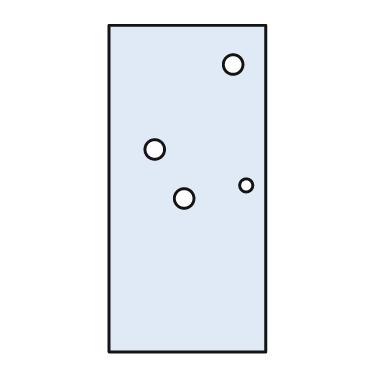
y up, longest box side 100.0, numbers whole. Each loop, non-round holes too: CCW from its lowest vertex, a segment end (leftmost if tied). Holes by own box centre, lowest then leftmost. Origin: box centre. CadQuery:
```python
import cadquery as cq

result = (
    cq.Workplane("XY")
    .moveTo(-24.0, -50.0)
    .lineTo(24.0, -50.0)
    .lineTo(24.0, 50.0)
    .lineTo(-24.0, 50.0)
    .close()
    .moveTo(-1.0, -3.0)
    .circle(3.0)
    .moveTo(18.0, 1.0)
    .circle(2.0)
    .moveTo(-10.0, 12.0)
    .circle(3.0)
    .moveTo(14.0, 38.0)
    .circle(3.0)
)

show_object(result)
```